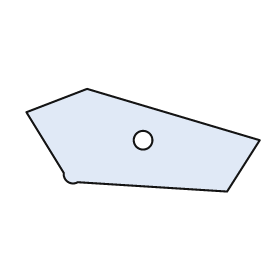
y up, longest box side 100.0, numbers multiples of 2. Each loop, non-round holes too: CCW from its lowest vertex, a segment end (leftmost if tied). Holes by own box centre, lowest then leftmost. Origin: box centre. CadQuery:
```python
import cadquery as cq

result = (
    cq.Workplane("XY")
    .moveTo(36.0, -22.0)
    .lineTo(50.0, 0.0)
    .lineTo(-24.0, 22.0)
    .lineTo(-50.0, 12.0)
    .lineTo(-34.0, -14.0)
    .threePointArc((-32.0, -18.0), (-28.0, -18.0))
    .close()
    .moveTo(0.0, 0.0)
    .circle(4.0)
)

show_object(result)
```